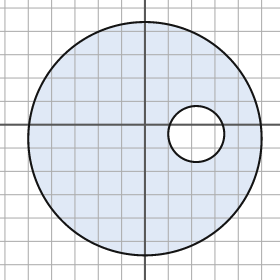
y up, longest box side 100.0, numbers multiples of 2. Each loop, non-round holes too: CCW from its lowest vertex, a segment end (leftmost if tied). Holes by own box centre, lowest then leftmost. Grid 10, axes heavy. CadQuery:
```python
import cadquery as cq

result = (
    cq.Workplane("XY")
    .moveTo(0.0, -6.0)
    .circle(50.0)
    .moveTo(22.0, -4.0)
    .circle(12.0)
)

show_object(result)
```